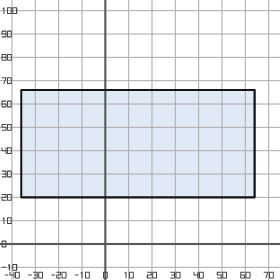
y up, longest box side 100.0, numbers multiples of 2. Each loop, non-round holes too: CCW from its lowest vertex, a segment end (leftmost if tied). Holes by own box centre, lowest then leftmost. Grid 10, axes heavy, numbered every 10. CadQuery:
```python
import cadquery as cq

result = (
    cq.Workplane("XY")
    .moveTo(-36.0, 20.0)
    .lineTo(64.0, 20.0)
    .lineTo(64.0, 66.0)
    .lineTo(-36.0, 66.0)
    .close()
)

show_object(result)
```